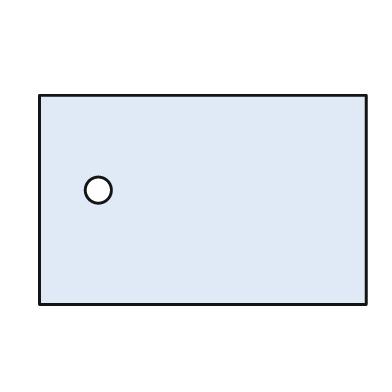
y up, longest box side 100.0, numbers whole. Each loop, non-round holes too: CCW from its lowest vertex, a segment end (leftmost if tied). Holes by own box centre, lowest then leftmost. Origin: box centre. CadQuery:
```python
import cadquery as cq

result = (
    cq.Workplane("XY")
    .moveTo(-50.0, -32.0)
    .lineTo(50.0, -32.0)
    .lineTo(50.0, 32.0)
    .lineTo(-50.0, 32.0)
    .close()
    .moveTo(-32.0, 3.0)
    .circle(4.0)
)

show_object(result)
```